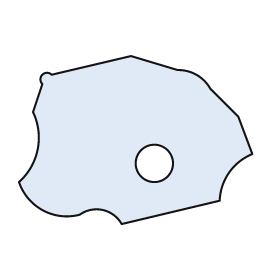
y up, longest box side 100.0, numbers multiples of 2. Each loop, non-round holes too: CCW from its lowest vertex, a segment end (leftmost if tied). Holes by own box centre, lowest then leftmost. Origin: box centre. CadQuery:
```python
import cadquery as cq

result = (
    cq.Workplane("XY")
    .moveTo(-6.0, -36.0)
    .lineTo(36.0, -26.0)
    .threePointArc((40.0, -14.0), (50.0, -6.0))
    .lineTo(44.0, 10.0)
    .lineTo(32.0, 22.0)
    .threePointArc((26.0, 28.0), (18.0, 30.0))
    .lineTo(-2.0, 36.0)
    .lineTo(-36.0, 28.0)
    .threePointArc((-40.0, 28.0), (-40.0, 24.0))
    .lineTo(-44.0, 12.0)
    .threePointArc((-42.0, -4.0), (-50.0, -18.0))
    .threePointArc((-40.0, -30.0), (-24.0, -32.0))
    .threePointArc((-14.0, -30.0), (-6.0, -36.0))
    .close()
    .moveTo(8.0, -10.0)
    .circle(8.0)
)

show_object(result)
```